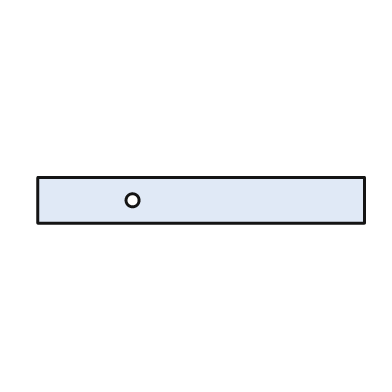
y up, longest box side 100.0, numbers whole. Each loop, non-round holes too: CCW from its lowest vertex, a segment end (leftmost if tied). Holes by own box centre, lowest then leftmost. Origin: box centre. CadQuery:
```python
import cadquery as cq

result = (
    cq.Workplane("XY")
    .moveTo(-50.0, -7.0)
    .lineTo(50.0, -7.0)
    .lineTo(50.0, 7.0)
    .lineTo(-50.0, 7.0)
    .close()
    .moveTo(-21.0, 0.0)
    .circle(2.0)
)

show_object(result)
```